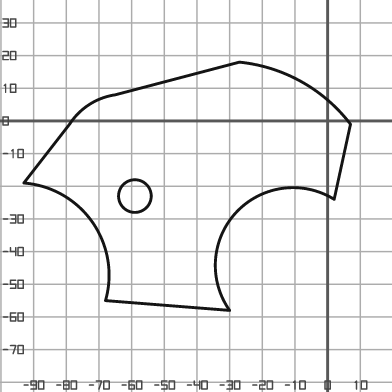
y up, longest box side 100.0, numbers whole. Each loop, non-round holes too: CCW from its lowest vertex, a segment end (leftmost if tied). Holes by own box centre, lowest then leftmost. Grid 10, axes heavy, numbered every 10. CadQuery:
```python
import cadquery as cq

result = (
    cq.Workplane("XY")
    .moveTo(-30.0, -58.0)
    .threePointArc((-28.0, -28.0), (2.0, -24.0))
    .lineTo(7.0, -1.0)
    .threePointArc((-8.0, 12.0), (-27.0, 18.0))
    .lineTo(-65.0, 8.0)
    .threePointArc((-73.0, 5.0), (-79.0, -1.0))
    .lineTo(-93.0, -19.0)
    .threePointArc((-72.0, -31.0), (-68.0, -55.0))
    .close()
    .moveTo(-59.0, -23.0)
    .circle(5.0)
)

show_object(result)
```